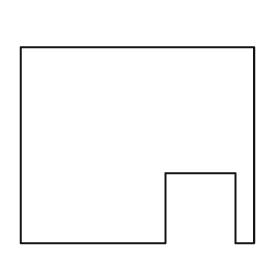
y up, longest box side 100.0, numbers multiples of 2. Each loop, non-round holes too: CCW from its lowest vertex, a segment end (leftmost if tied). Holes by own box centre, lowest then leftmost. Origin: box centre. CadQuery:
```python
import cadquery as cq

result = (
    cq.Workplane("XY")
    .moveTo(-50.0, -42.0)
    .lineTo(12.0, -42.0)
    .lineTo(12.0, -12.0)
    .lineTo(42.0, -12.0)
    .lineTo(42.0, -42.0)
    .lineTo(50.0, -42.0)
    .lineTo(50.0, 42.0)
    .lineTo(-50.0, 42.0)
    .close()
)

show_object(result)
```